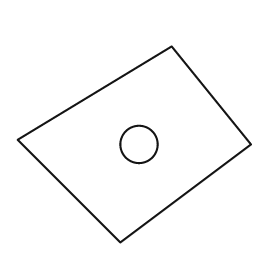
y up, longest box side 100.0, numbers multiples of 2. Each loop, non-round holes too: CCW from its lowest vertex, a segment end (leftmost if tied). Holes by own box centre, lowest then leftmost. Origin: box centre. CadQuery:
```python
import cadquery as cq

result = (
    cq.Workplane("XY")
    .moveTo(-6.0, -42.0)
    .lineTo(50.0, 0.0)
    .lineTo(16.0, 42.0)
    .lineTo(-50.0, 2.0)
    .close()
    .moveTo(2.0, 0.0)
    .circle(8.0)
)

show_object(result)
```